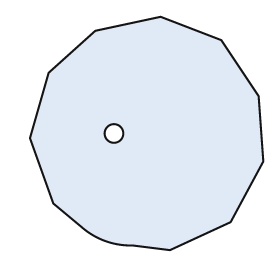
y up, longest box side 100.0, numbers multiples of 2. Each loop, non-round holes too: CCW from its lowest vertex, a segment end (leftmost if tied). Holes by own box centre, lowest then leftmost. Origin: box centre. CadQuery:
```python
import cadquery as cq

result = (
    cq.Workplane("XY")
    .moveTo(10.0, -50.0)
    .lineTo(36.0, -38.0)
    .lineTo(50.0, -12.0)
    .lineTo(48.0, 16.0)
    .lineTo(32.0, 40.0)
    .lineTo(6.0, 50.0)
    .lineTo(-22.0, 44.0)
    .lineTo(-42.0, 26.0)
    .lineTo(-50.0, -2.0)
    .lineTo(-40.0, -30.0)
    .lineTo(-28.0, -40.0)
    .threePointArc((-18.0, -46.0), (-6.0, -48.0))
    .close()
    .moveTo(-14.0, 0.0)
    .circle(4.0)
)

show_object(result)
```